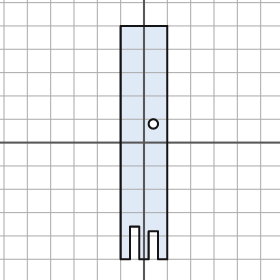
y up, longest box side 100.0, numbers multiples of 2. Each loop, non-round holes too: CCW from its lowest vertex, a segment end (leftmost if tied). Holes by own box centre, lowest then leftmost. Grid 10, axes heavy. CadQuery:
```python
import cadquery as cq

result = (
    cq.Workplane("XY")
    .moveTo(-10.0, -50.0)
    .lineTo(-6.0, -50.0)
    .lineTo(-6.0, -36.0)
    .lineTo(-2.0, -36.0)
    .lineTo(-2.0, -50.0)
    .lineTo(2.0, -50.0)
    .lineTo(2.0, -38.0)
    .lineTo(6.0, -38.0)
    .lineTo(6.0, -50.0)
    .lineTo(10.0, -50.0)
    .lineTo(10.0, 50.0)
    .lineTo(-10.0, 50.0)
    .close()
    .moveTo(4.0, 8.0)
    .circle(2.0)
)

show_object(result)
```